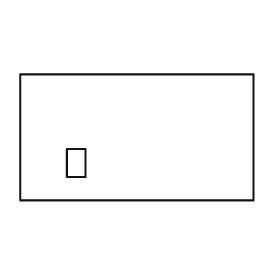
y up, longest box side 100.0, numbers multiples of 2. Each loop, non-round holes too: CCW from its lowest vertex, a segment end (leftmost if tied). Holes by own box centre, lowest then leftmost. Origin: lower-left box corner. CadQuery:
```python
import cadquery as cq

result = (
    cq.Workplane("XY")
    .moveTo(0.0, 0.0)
    .lineTo(100.0, 0.0)
    .lineTo(100.0, 54.0)
    .lineTo(0.0, 54.0)
    .close()
    .moveTo(20.0, 10.0)
    .lineTo(28.0, 10.0)
    .lineTo(28.0, 22.0)
    .lineTo(20.0, 22.0)
    .close()
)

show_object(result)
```